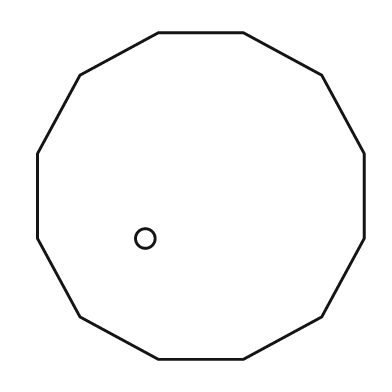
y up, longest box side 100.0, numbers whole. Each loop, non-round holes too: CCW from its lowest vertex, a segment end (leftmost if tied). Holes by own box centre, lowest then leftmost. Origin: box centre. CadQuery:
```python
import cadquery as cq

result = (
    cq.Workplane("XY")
    .moveTo(-13.0, -50.0)
    .lineTo(13.0, -50.0)
    .lineTo(37.0, -37.0)
    .lineTo(50.0, -13.0)
    .lineTo(50.0, 13.0)
    .lineTo(37.0, 37.0)
    .lineTo(13.0, 50.0)
    .lineTo(-13.0, 50.0)
    .lineTo(-37.0, 37.0)
    .lineTo(-50.0, 13.0)
    .lineTo(-50.0, -13.0)
    .lineTo(-37.0, -37.0)
    .close()
    .moveTo(-17.0, -13.0)
    .circle(3.0)
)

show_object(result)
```